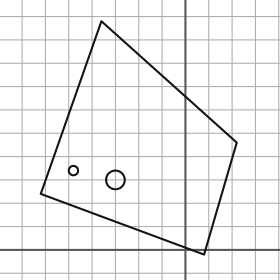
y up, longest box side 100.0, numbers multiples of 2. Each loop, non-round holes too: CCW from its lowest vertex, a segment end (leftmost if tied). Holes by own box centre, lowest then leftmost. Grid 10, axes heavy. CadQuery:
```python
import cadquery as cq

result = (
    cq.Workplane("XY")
    .moveTo(8.0, -2.0)
    .lineTo(22.0, 46.0)
    .lineTo(-36.0, 98.0)
    .lineTo(-62.0, 24.0)
    .close()
    .moveTo(-30.0, 30.0)
    .circle(4.0)
    .moveTo(-48.0, 34.0)
    .circle(2.0)
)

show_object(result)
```